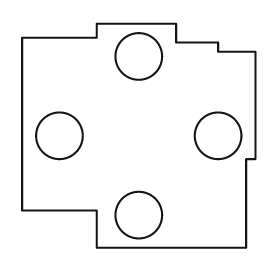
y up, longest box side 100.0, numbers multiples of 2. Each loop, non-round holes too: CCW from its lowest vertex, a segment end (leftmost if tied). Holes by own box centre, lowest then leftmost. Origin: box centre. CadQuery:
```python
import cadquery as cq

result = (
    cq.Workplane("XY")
    .moveTo(-18.0, -48.0)
    .lineTo(46.0, -48.0)
    .lineTo(46.0, -10.0)
    .lineTo(50.0, -10.0)
    .lineTo(50.0, 36.0)
    .lineTo(34.0, 36.0)
    .lineTo(34.0, 40.0)
    .lineTo(16.0, 40.0)
    .lineTo(16.0, 48.0)
    .lineTo(-18.0, 48.0)
    .lineTo(-18.0, 42.0)
    .lineTo(-50.0, 42.0)
    .lineTo(-50.0, -32.0)
    .lineTo(-18.0, -32.0)
    .close()
    .moveTo(0.0, -34.0)
    .circle(10.0)
    .moveTo(-34.0, 0.0)
    .circle(10.0)
    .moveTo(34.0, 0.0)
    .circle(10.0)
    .moveTo(0.0, 34.0)
    .circle(10.0)
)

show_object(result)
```